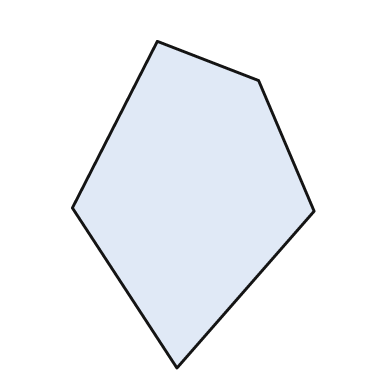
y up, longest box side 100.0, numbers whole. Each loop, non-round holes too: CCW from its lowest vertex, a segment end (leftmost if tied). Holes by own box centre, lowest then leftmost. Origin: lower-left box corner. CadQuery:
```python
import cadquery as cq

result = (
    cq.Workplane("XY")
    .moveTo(32.0, 0.0)
    .lineTo(74.0, 48.0)
    .lineTo(57.0, 88.0)
    .lineTo(26.0, 100.0)
    .lineTo(0.0, 49.0)
    .close()
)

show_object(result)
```